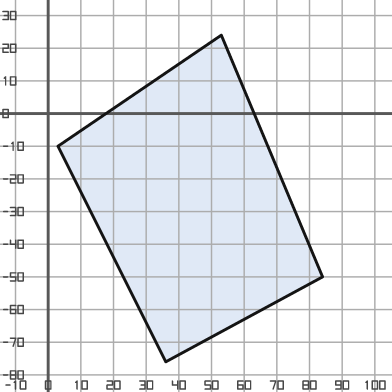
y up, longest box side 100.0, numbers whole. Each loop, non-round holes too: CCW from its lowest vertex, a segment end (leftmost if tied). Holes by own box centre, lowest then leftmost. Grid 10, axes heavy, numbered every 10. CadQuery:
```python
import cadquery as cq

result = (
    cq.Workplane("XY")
    .moveTo(36.0, -76.0)
    .lineTo(84.0, -50.0)
    .lineTo(53.0, 24.0)
    .lineTo(3.0, -10.0)
    .close()
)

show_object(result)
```